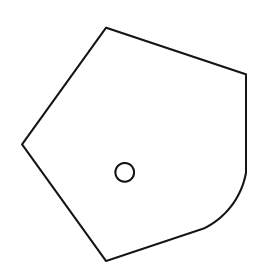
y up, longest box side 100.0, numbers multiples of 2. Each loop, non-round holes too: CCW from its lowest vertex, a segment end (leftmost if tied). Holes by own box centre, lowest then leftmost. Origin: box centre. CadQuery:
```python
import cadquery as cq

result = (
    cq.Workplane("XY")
    .moveTo(-12.0, -50.0)
    .lineTo(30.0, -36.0)
    .threePointArc((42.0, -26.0), (48.0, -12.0))
    .lineTo(48.0, 30.0)
    .lineTo(-12.0, 50.0)
    .lineTo(-48.0, 0.0)
    .close()
    .moveTo(-4.0, -12.0)
    .circle(4.0)
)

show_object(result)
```